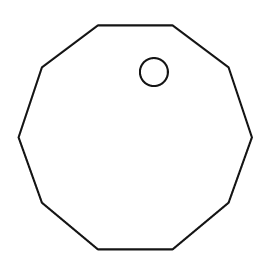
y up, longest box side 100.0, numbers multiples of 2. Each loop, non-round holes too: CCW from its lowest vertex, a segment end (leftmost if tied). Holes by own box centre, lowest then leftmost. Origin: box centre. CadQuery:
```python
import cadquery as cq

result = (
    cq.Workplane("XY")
    .moveTo(-16.0, -48.0)
    .lineTo(16.0, -48.0)
    .lineTo(40.0, -28.0)
    .lineTo(50.0, 0.0)
    .lineTo(40.0, 30.0)
    .lineTo(16.0, 48.0)
    .lineTo(-16.0, 48.0)
    .lineTo(-40.0, 30.0)
    .lineTo(-50.0, 0.0)
    .lineTo(-40.0, -28.0)
    .close()
    .moveTo(8.0, 28.0)
    .circle(6.0)
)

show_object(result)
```